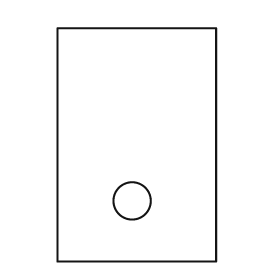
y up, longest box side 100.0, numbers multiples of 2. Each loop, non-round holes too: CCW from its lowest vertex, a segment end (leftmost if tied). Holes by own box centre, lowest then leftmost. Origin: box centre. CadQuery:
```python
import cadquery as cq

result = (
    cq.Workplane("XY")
    .moveTo(-34.0, -50.0)
    .lineTo(34.0, -50.0)
    .lineTo(34.0, 50.0)
    .lineTo(-34.0, 50.0)
    .close()
    .moveTo(-2.0, -24.0)
    .circle(8.0)
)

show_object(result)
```